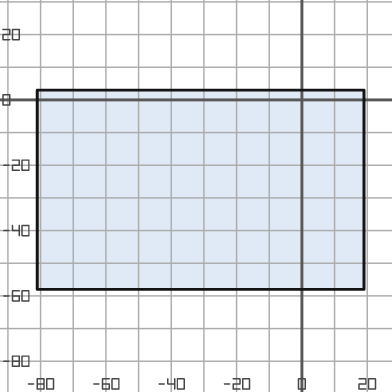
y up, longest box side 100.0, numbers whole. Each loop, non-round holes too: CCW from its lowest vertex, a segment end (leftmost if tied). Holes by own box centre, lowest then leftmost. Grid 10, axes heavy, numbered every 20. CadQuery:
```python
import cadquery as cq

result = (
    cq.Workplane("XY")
    .moveTo(-81.0, -58.0)
    .lineTo(19.0, -58.0)
    .lineTo(19.0, 3.0)
    .lineTo(-81.0, 3.0)
    .close()
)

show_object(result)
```